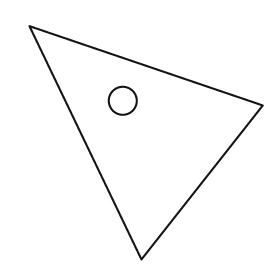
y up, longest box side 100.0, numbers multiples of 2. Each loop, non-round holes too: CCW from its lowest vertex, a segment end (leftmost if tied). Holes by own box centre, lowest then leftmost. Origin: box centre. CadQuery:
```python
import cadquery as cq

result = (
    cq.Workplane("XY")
    .moveTo(-2.0, -50.0)
    .lineTo(50.0, 16.0)
    .lineTo(-50.0, 50.0)
    .close()
    .moveTo(-10.0, 18.0)
    .circle(6.0)
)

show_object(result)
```